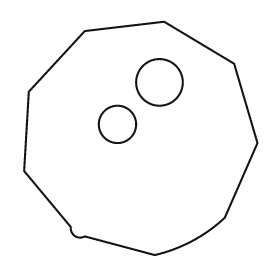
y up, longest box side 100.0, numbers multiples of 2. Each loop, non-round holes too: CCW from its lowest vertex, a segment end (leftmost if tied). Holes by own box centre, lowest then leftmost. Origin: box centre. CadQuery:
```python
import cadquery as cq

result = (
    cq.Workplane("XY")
    .moveTo(6.0, -50.0)
    .threePointArc((22.0, -44.0), (36.0, -34.0))
    .lineTo(50.0, -2.0)
    .lineTo(40.0, 32.0)
    .lineTo(10.0, 50.0)
    .lineTo(-24.0, 46.0)
    .lineTo(-48.0, 20.0)
    .lineTo(-50.0, -14.0)
    .lineTo(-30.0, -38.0)
    .threePointArc((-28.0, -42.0), (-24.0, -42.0))
    .close()
    .moveTo(-10.0, 6.0)
    .circle(8.0)
    .moveTo(8.0, 24.0)
    .circle(10.0)
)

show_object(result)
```